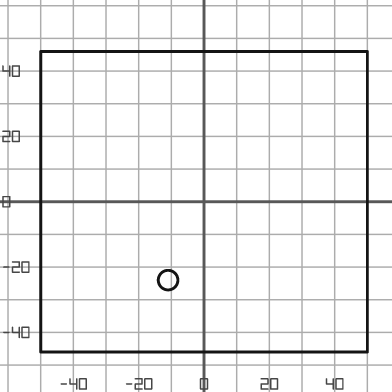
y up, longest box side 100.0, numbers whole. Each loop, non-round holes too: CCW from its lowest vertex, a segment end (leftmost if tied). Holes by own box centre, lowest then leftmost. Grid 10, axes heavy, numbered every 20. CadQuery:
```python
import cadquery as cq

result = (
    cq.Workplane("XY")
    .moveTo(-50.0, -46.0)
    .lineTo(50.0, -46.0)
    .lineTo(50.0, 46.0)
    .lineTo(-50.0, 46.0)
    .close()
    .moveTo(-11.0, -24.0)
    .circle(3.0)
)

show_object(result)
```